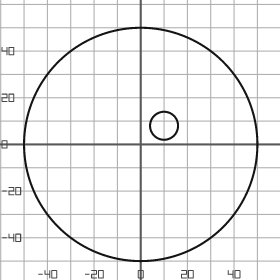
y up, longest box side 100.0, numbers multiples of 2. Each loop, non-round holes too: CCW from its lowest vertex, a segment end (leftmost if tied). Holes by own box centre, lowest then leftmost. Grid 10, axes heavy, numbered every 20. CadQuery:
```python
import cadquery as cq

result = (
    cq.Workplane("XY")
    .moveTo(0.0, 0.0)
    .circle(50.0)
    .moveTo(10.0, 8.0)
    .circle(6.0)
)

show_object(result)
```